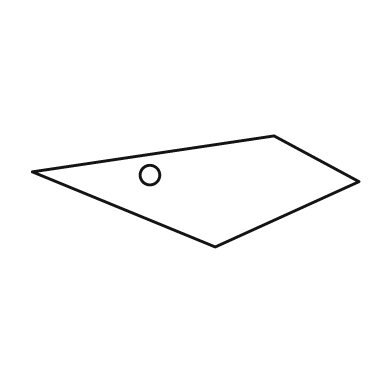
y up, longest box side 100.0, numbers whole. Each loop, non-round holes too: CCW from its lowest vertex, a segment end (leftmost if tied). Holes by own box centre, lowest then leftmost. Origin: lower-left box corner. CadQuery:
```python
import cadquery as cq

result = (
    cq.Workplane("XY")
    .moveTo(56.0, 0.0)
    .lineTo(100.0, 20.0)
    .lineTo(74.0, 34.0)
    .lineTo(0.0, 23.0)
    .close()
    .moveTo(36.0, 22.0)
    .circle(3.0)
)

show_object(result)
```